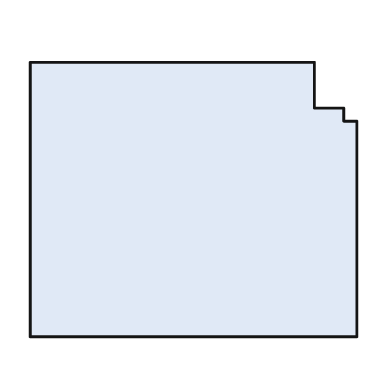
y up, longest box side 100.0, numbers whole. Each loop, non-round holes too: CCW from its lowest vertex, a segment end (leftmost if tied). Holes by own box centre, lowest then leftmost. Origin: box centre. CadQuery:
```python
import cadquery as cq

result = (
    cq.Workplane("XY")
    .moveTo(-50.0, -42.0)
    .lineTo(50.0, -42.0)
    .lineTo(50.0, 24.0)
    .lineTo(46.0, 24.0)
    .lineTo(46.0, 28.0)
    .lineTo(37.0, 28.0)
    .lineTo(37.0, 42.0)
    .lineTo(-50.0, 42.0)
    .close()
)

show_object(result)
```